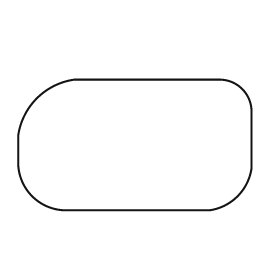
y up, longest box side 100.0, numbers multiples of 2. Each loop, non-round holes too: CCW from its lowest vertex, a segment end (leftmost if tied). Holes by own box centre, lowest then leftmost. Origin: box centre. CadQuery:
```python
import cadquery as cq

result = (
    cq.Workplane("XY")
    .moveTo(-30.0, -28.0)
    .lineTo(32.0, -28.0)
    .threePointArc((44.0, -22.0), (50.0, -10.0))
    .lineTo(50.0, 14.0)
    .threePointArc((46.0, 24.0), (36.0, 28.0))
    .lineTo(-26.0, 28.0)
    .threePointArc((-42.0, 20.0), (-50.0, 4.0))
    .lineTo(-50.0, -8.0)
    .threePointArc((-44.0, -22.0), (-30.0, -28.0))
    .close()
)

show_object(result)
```